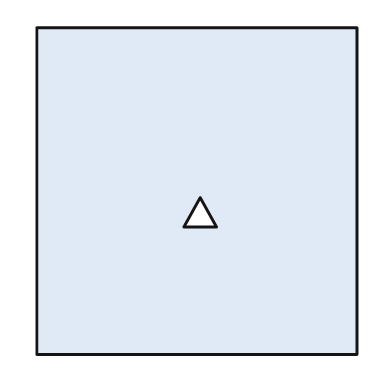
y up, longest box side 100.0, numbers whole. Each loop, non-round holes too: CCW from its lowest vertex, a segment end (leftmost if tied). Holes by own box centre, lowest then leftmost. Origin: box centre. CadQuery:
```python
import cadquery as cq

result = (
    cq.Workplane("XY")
    .moveTo(-49.0, -50.0)
    .lineTo(49.0, -50.0)
    .lineTo(49.0, 50.0)
    .lineTo(-49.0, 50.0)
    .close()
    .moveTo(-4.0, -11.0)
    .lineTo(6.0, -11.0)
    .lineTo(1.0, -2.0)
    .close()
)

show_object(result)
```